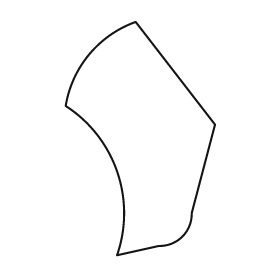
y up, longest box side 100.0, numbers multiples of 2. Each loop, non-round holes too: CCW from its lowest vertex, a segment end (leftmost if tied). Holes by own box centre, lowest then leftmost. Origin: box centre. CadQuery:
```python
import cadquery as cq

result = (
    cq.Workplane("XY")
    .moveTo(-10.0, -50.0)
    .lineTo(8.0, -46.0)
    .threePointArc((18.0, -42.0), (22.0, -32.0))
    .lineTo(32.0, 6.0)
    .lineTo(-2.0, 50.0)
    .threePointArc((-22.0, 36.0), (-32.0, 14.0))
    .threePointArc((-10.0, -14.0), (-10.0, -50.0))
    .close()
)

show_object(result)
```